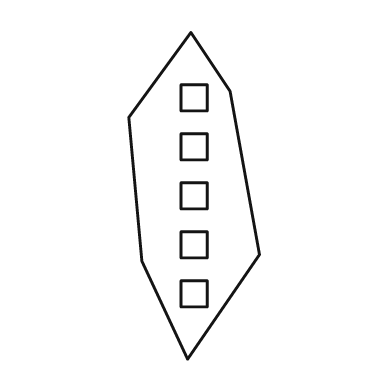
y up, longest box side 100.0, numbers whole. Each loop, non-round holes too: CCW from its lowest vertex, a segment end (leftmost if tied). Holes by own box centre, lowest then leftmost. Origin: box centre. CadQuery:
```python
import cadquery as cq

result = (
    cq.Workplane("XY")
    .moveTo(-2.0, -50.0)
    .lineTo(20.0, -18.0)
    .lineTo(11.0, 32.0)
    .lineTo(-1.0, 50.0)
    .lineTo(-20.0, 24.0)
    .lineTo(-16.0, -20.0)
    .close()
    .moveTo(-4.0, -34.0)
    .lineTo(4.0, -34.0)
    .lineTo(4.0, -26.0)
    .lineTo(-4.0, -26.0)
    .close()
    .moveTo(-4.0, -19.0)
    .lineTo(4.0, -19.0)
    .lineTo(4.0, -11.0)
    .lineTo(-4.0, -11.0)
    .close()
    .moveTo(-4.0, -4.0)
    .lineTo(4.0, -4.0)
    .lineTo(4.0, 4.0)
    .lineTo(-4.0, 4.0)
    .close()
    .moveTo(-4.0, 11.0)
    .lineTo(4.0, 11.0)
    .lineTo(4.0, 19.0)
    .lineTo(-4.0, 19.0)
    .close()
    .moveTo(-4.0, 26.0)
    .lineTo(4.0, 26.0)
    .lineTo(4.0, 34.0)
    .lineTo(-4.0, 34.0)
    .close()
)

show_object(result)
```